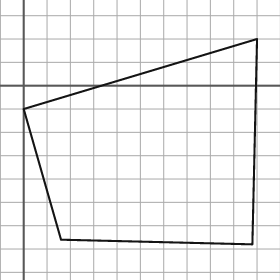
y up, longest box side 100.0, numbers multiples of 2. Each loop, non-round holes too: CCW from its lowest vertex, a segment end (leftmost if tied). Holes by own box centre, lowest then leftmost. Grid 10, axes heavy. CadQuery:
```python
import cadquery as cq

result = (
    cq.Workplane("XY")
    .moveTo(98.0, -68.0)
    .lineTo(100.0, 20.0)
    .lineTo(0.0, -10.0)
    .lineTo(16.0, -66.0)
    .close()
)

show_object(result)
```